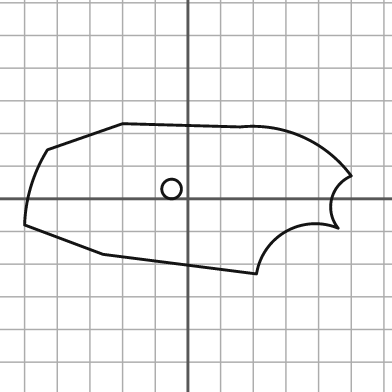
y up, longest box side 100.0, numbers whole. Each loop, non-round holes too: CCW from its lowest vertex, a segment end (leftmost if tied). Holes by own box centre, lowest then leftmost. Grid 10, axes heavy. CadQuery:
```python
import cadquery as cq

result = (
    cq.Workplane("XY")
    .moveTo(21.0, -23.0)
    .threePointArc((30.0, -10.0), (46.0, -9.0))
    .threePointArc((44.0, 0.0), (50.0, 7.0))
    .threePointArc((35.0, 19.0), (16.0, 22.0))
    .lineTo(-20.0, 23.0)
    .lineTo(-43.0, 15.0)
    .threePointArc((-48.0, 4.0), (-50.0, -8.0))
    .lineTo(-26.0, -17.0)
    .close()
    .moveTo(-5.0, 3.0)
    .circle(3.0)
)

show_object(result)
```